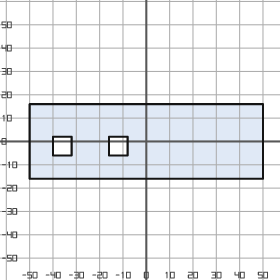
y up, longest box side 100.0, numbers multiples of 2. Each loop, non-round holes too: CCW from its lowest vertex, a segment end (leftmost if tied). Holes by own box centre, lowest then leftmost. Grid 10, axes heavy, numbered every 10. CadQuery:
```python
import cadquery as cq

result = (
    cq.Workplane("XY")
    .moveTo(-50.0, -16.0)
    .lineTo(50.0, -16.0)
    .lineTo(50.0, 16.0)
    .lineTo(-50.0, 16.0)
    .close()
    .moveTo(-40.0, -6.0)
    .lineTo(-32.0, -6.0)
    .lineTo(-32.0, 2.0)
    .lineTo(-40.0, 2.0)
    .close()
    .moveTo(-16.0, -6.0)
    .lineTo(-8.0, -6.0)
    .lineTo(-8.0, 2.0)
    .lineTo(-16.0, 2.0)
    .close()
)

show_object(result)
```